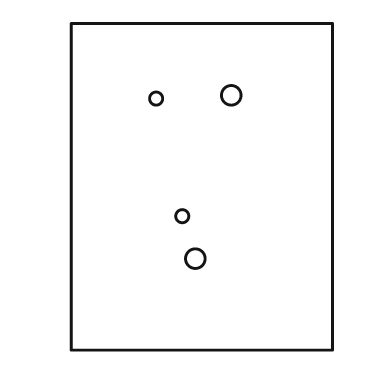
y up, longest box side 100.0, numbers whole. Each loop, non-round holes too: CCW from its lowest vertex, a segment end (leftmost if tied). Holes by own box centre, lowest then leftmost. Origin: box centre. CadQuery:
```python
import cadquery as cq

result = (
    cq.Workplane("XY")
    .moveTo(-40.0, -50.0)
    .lineTo(40.0, -50.0)
    .lineTo(40.0, 50.0)
    .lineTo(-40.0, 50.0)
    .close()
    .moveTo(-2.0, -22.0)
    .circle(3.0)
    .moveTo(-6.0, -9.0)
    .circle(2.0)
    .moveTo(-14.0, 27.0)
    .circle(2.0)
    .moveTo(9.0, 28.0)
    .circle(3.0)
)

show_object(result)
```